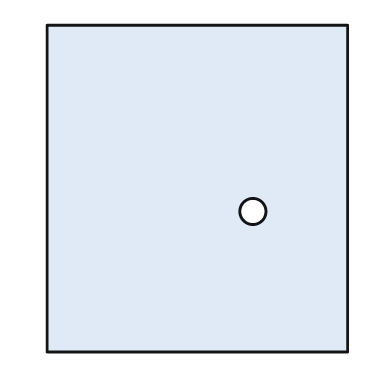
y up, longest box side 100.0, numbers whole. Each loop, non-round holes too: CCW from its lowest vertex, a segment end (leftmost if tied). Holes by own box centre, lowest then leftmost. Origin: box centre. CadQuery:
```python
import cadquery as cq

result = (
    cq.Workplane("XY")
    .moveTo(-46.0, -50.0)
    .lineTo(46.0, -50.0)
    .lineTo(46.0, 50.0)
    .lineTo(-46.0, 50.0)
    .close()
    .moveTo(17.0, -7.0)
    .circle(4.0)
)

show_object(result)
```